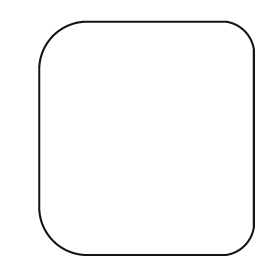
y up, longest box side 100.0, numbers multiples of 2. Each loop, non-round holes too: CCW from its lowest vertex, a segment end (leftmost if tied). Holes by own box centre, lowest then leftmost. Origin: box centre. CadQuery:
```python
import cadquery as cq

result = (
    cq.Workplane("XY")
    .moveTo(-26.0, -50.0)
    .lineTo(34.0, -50.0)
    .threePointArc((42.0, -46.0), (46.0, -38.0))
    .lineTo(46.0, 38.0)
    .threePointArc((42.0, 46.0), (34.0, 50.0))
    .lineTo(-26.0, 50.0)
    .threePointArc((-40.0, 44.0), (-46.0, 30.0))
    .lineTo(-46.0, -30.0)
    .threePointArc((-40.0, -44.0), (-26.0, -50.0))
    .close()
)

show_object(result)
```